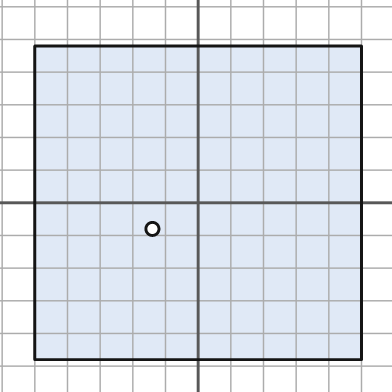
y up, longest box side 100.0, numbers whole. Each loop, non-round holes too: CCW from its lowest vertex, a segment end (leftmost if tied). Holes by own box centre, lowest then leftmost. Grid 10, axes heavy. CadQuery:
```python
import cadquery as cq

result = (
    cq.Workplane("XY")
    .moveTo(-50.0, -48.0)
    .lineTo(50.0, -48.0)
    .lineTo(50.0, 48.0)
    .lineTo(-50.0, 48.0)
    .close()
    .moveTo(-14.0, -8.0)
    .circle(2.0)
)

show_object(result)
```